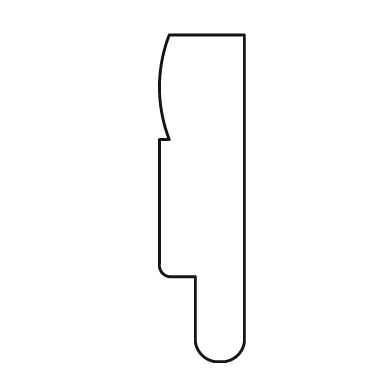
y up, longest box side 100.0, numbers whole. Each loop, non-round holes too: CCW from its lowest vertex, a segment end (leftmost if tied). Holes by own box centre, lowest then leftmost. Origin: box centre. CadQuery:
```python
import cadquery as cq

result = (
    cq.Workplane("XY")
    .moveTo(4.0, -50.0)
    .lineTo(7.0, -50.0)
    .threePointArc((11.0, -48.0), (13.0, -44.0))
    .lineTo(13.0, 50.0)
    .lineTo(-10.0, 50.0)
    .threePointArc((-13.0, 34.0), (-10.0, 18.0))
    .lineTo(-13.0, 18.0)
    .lineTo(-13.0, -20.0)
    .threePointArc((-12.0, -23.0), (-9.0, -24.0))
    .lineTo(-2.0, -24.0)
    .lineTo(-2.0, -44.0)
    .threePointArc((0.0, -48.0), (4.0, -50.0))
    .close()
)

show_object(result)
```